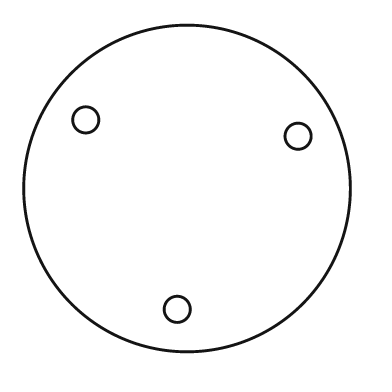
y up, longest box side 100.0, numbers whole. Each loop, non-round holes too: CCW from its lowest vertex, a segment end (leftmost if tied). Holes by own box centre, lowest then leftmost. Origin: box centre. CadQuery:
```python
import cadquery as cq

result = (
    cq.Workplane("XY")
    .moveTo(0.0, 0.0)
    .circle(50.0)
    .moveTo(-3.0, -37.0)
    .circle(4.0)
    .moveTo(34.0, 16.0)
    .circle(4.0)
    .moveTo(-31.0, 21.0)
    .circle(4.0)
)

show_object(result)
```